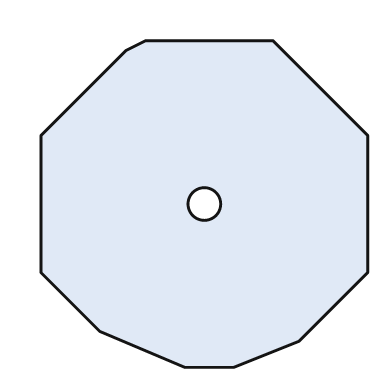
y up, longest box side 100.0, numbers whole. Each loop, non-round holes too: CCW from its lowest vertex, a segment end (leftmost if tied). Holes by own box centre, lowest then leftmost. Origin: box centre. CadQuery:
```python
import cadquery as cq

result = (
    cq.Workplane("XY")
    .moveTo(-6.0, -50.0)
    .lineTo(9.0, -50.0)
    .lineTo(29.0, -42.0)
    .lineTo(50.0, -21.0)
    .lineTo(50.0, 21.0)
    .lineTo(21.0, 50.0)
    .lineTo(-18.0, 50.0)
    .lineTo(-24.0, 47.0)
    .lineTo(-50.0, 21.0)
    .lineTo(-50.0, -21.0)
    .lineTo(-32.0, -39.0)
    .close()
    .moveTo(0.0, 0.0)
    .circle(5.0)
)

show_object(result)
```